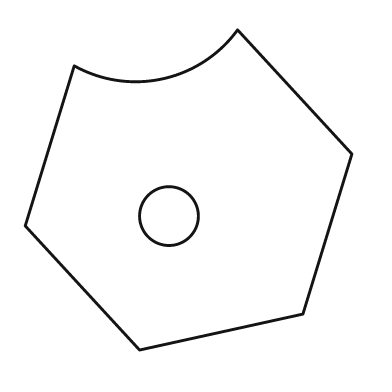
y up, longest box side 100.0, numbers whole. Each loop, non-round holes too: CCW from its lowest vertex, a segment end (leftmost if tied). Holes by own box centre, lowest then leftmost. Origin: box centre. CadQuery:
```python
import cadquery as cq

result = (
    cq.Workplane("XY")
    .moveTo(-15.0, -49.0)
    .lineTo(35.0, -38.0)
    .lineTo(50.0, 11.0)
    .lineTo(15.0, 49.0)
    .threePointArc((-8.0, 34.0), (-35.0, 38.0))
    .lineTo(-50.0, -11.0)
    .close()
    .moveTo(-6.0, -8.0)
    .circle(9.0)
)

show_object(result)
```